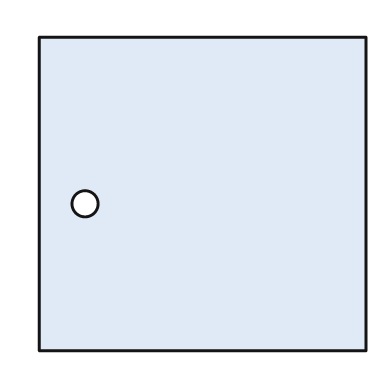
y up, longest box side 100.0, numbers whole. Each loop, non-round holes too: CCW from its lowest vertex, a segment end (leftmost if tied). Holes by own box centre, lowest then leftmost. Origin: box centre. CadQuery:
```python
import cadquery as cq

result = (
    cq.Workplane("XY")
    .moveTo(-50.0, -48.0)
    .lineTo(50.0, -48.0)
    .lineTo(50.0, 48.0)
    .lineTo(-50.0, 48.0)
    .close()
    .moveTo(-36.0, -3.0)
    .circle(4.0)
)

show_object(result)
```